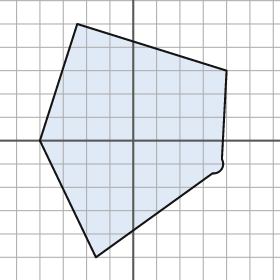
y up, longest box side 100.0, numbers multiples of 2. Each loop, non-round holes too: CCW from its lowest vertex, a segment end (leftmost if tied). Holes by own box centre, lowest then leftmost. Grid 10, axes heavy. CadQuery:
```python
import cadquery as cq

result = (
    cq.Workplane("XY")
    .moveTo(-16.0, -50.0)
    .lineTo(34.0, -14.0)
    .threePointArc((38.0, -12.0), (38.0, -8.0))
    .lineTo(40.0, 30.0)
    .lineTo(-24.0, 50.0)
    .lineTo(-40.0, 0.0)
    .close()
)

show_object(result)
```